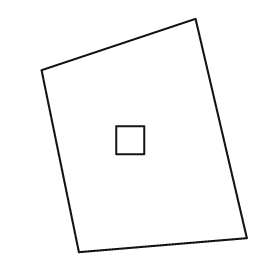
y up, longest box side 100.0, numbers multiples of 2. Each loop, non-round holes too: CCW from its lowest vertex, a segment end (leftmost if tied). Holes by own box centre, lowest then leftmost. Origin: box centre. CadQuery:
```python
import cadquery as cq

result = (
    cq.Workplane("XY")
    .moveTo(-28.0, -50.0)
    .lineTo(44.0, -44.0)
    .lineTo(22.0, 50.0)
    .lineTo(-44.0, 28.0)
    .close()
    .moveTo(-12.0, -8.0)
    .lineTo(0.0, -8.0)
    .lineTo(0.0, 4.0)
    .lineTo(-12.0, 4.0)
    .close()
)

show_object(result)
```